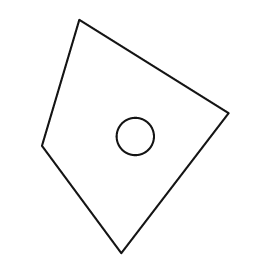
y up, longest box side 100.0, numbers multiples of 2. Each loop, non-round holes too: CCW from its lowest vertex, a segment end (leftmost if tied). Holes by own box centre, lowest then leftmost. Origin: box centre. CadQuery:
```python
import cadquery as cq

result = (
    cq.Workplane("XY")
    .moveTo(-6.0, -50.0)
    .lineTo(40.0, 10.0)
    .lineTo(-24.0, 50.0)
    .lineTo(-40.0, -4.0)
    .close()
    .moveTo(0.0, 0.0)
    .circle(8.0)
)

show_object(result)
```